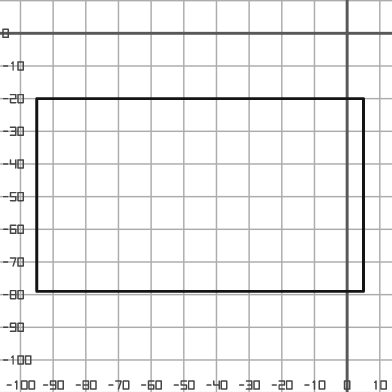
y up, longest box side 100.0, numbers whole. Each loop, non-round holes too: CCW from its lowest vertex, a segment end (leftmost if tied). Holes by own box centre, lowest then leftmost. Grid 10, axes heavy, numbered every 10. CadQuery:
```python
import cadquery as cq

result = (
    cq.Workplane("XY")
    .moveTo(-95.0, -79.0)
    .lineTo(5.0, -79.0)
    .lineTo(5.0, -20.0)
    .lineTo(-95.0, -20.0)
    .close()
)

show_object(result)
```